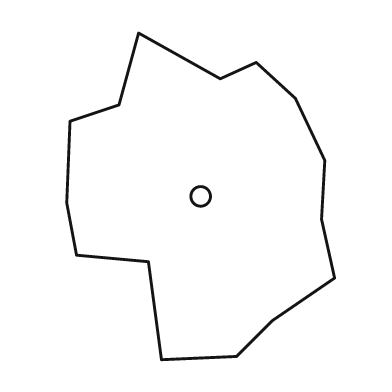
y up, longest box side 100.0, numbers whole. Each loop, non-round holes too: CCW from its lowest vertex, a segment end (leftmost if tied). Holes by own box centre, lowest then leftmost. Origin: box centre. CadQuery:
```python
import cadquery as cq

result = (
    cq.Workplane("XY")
    .moveTo(-12.0, -50.0)
    .lineTo(11.0, -49.0)
    .lineTo(22.0, -38.0)
    .lineTo(41.0, -25.0)
    .lineTo(37.0, -7.0)
    .lineTo(38.0, 11.0)
    .lineTo(29.0, 30.0)
    .lineTo(17.0, 41.0)
    .lineTo(6.0, 36.0)
    .lineTo(-19.0, 50.0)
    .lineTo(-25.0, 28.0)
    .lineTo(-40.0, 23.0)
    .lineTo(-41.0, -2.0)
    .lineTo(-38.0, -18.0)
    .lineTo(-16.0, -20.0)
    .close()
    .moveTo(0.0, 0.0)
    .circle(3.0)
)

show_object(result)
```